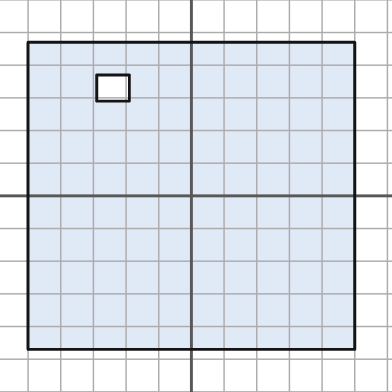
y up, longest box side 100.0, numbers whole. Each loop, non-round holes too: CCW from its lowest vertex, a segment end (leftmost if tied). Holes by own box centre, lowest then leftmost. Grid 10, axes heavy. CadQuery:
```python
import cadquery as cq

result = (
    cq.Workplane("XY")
    .moveTo(-50.0, -47.0)
    .lineTo(50.0, -47.0)
    .lineTo(50.0, 47.0)
    .lineTo(-50.0, 47.0)
    .close()
    .moveTo(-29.0, 29.0)
    .lineTo(-19.0, 29.0)
    .lineTo(-19.0, 37.0)
    .lineTo(-29.0, 37.0)
    .close()
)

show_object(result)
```